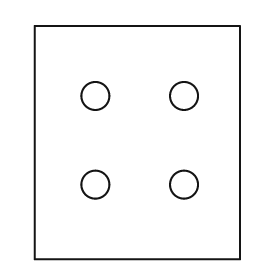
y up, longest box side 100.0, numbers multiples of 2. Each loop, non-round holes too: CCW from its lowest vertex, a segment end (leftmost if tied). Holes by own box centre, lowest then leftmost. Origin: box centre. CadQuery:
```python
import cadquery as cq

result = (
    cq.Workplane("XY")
    .moveTo(-44.0, -50.0)
    .lineTo(44.0, -50.0)
    .lineTo(44.0, 50.0)
    .lineTo(-44.0, 50.0)
    .close()
    .moveTo(-18.0, -18.0)
    .circle(6.0)
    .moveTo(20.0, -18.0)
    .circle(6.0)
    .moveTo(-18.0, 20.0)
    .circle(6.0)
    .moveTo(20.0, 20.0)
    .circle(6.0)
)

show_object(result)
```